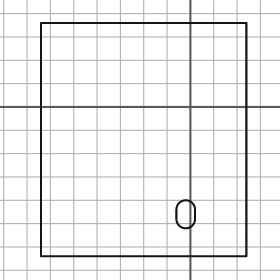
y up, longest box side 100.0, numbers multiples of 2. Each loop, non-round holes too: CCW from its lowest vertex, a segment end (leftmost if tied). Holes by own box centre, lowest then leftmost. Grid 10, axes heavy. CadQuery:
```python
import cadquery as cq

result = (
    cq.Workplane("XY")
    .moveTo(-64.0, -64.0)
    .lineTo(24.0, -64.0)
    .lineTo(24.0, 36.0)
    .lineTo(-64.0, 36.0)
    .close()
    .moveTo(-6.0, -48.0)
    .threePointArc((-2.0, -52.0), (2.0, -48.0))
    .lineTo(2.0, -44.0)
    .threePointArc((-2.0, -40.0), (-6.0, -44.0))
    .close()
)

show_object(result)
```